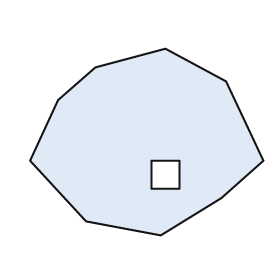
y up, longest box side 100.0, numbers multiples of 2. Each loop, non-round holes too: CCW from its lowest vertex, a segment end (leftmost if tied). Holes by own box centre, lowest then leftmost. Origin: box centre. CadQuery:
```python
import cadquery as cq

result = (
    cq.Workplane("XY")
    .moveTo(6.0, -40.0)
    .lineTo(32.0, -24.0)
    .lineTo(50.0, -8.0)
    .lineTo(34.0, 26.0)
    .lineTo(8.0, 40.0)
    .lineTo(-22.0, 32.0)
    .lineTo(-38.0, 18.0)
    .lineTo(-50.0, -8.0)
    .lineTo(-26.0, -34.0)
    .close()
    .moveTo(2.0, -20.0)
    .lineTo(14.0, -20.0)
    .lineTo(14.0, -8.0)
    .lineTo(2.0, -8.0)
    .close()
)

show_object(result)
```